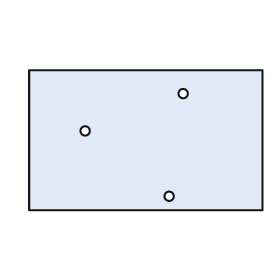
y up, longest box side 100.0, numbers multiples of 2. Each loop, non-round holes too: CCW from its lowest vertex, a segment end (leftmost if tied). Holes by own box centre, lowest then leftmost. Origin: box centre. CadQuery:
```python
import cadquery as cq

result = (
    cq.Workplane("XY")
    .moveTo(-50.0, -30.0)
    .lineTo(50.0, -30.0)
    .lineTo(50.0, 30.0)
    .lineTo(-50.0, 30.0)
    .close()
    .moveTo(10.0, -24.0)
    .circle(2.0)
    .moveTo(-26.0, 4.0)
    .circle(2.0)
    .moveTo(16.0, 20.0)
    .circle(2.0)
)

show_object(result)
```